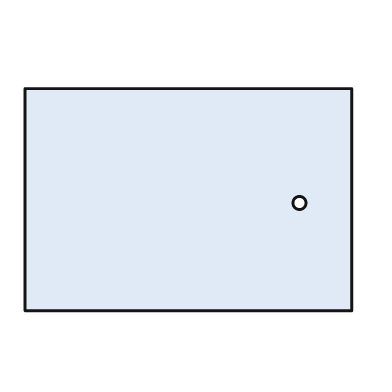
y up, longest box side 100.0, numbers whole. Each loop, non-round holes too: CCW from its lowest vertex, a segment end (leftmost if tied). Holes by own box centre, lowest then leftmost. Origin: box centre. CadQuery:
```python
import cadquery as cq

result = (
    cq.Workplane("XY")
    .moveTo(-50.0, -34.0)
    .lineTo(50.0, -34.0)
    .lineTo(50.0, 34.0)
    .lineTo(-50.0, 34.0)
    .close()
    .moveTo(34.0, -1.0)
    .circle(2.0)
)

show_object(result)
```